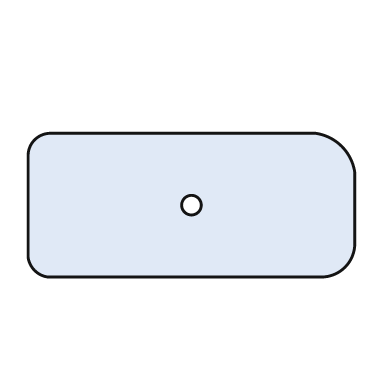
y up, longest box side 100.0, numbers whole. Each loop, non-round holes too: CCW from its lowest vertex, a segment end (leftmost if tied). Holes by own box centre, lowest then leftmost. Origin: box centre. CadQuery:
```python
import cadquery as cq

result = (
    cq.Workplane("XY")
    .moveTo(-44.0, -22.0)
    .lineTo(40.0, -22.0)
    .threePointArc((47.0, -19.0), (50.0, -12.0))
    .lineTo(50.0, 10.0)
    .threePointArc((46.0, 18.0), (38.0, 22.0))
    .lineTo(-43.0, 22.0)
    .threePointArc((-48.0, 20.0), (-50.0, 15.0))
    .lineTo(-50.0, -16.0)
    .threePointArc((-48.0, -20.0), (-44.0, -22.0))
    .close()
    .moveTo(0.0, 0.0)
    .circle(3.0)
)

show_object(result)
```